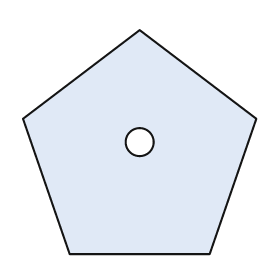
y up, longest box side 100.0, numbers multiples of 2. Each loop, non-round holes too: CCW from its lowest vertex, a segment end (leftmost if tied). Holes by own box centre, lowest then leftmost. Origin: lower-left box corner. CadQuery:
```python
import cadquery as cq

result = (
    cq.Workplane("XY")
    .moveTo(20.0, 0.0)
    .lineTo(80.0, 0.0)
    .lineTo(100.0, 58.0)
    .lineTo(50.0, 96.0)
    .lineTo(0.0, 58.0)
    .close()
    .moveTo(50.0, 48.0)
    .circle(6.0)
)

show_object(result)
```